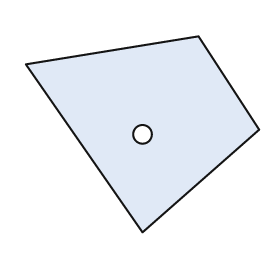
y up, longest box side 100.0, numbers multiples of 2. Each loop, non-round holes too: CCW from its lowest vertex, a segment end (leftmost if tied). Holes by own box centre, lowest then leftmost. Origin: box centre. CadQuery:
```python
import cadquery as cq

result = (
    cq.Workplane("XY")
    .moveTo(0.0, -42.0)
    .lineTo(50.0, 2.0)
    .lineTo(24.0, 42.0)
    .lineTo(-50.0, 30.0)
    .close()
    .moveTo(0.0, 0.0)
    .circle(4.0)
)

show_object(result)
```